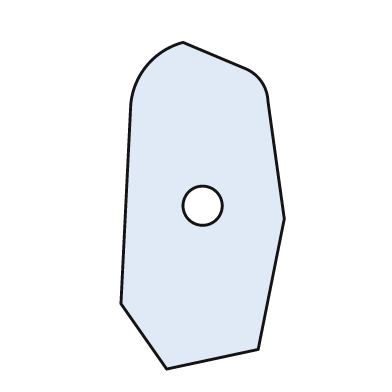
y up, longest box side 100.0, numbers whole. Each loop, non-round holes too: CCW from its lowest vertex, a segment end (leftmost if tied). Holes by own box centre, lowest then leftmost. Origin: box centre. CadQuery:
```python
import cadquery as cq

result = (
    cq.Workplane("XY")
    .moveTo(-11.0, -50.0)
    .lineTo(17.0, -44.0)
    .lineTo(25.0, -4.0)
    .lineTo(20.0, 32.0)
    .threePointArc((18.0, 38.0), (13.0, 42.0))
    .lineTo(-6.0, 50.0)
    .threePointArc((-17.0, 43.0), (-22.0, 31.0))
    .lineTo(-25.0, -30.0)
    .close()
    .moveTo(0.0, 0.0)
    .circle(6.0)
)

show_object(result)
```